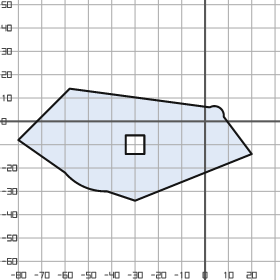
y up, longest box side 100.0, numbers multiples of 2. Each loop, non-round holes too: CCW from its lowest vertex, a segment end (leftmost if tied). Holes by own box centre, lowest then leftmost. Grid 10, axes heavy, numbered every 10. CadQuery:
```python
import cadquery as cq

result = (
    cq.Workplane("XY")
    .moveTo(-30.0, -34.0)
    .lineTo(20.0, -14.0)
    .lineTo(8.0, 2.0)
    .threePointArc((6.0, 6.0), (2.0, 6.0))
    .lineTo(-58.0, 14.0)
    .lineTo(-80.0, -8.0)
    .lineTo(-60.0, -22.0)
    .threePointArc((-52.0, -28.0), (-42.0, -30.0))
    .close()
    .moveTo(-34.0, -14.0)
    .lineTo(-26.0, -14.0)
    .lineTo(-26.0, -6.0)
    .lineTo(-34.0, -6.0)
    .close()
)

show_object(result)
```